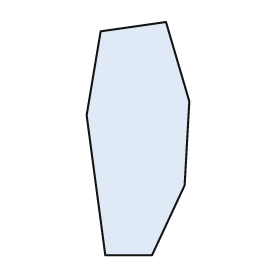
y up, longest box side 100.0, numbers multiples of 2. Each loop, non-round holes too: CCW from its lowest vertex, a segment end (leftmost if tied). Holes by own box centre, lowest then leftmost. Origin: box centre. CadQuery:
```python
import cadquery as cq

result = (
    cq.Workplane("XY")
    .moveTo(-14.0, -50.0)
    .lineTo(6.0, -50.0)
    .lineTo(20.0, -20.0)
    .lineTo(22.0, 16.0)
    .lineTo(12.0, 50.0)
    .lineTo(-16.0, 46.0)
    .lineTo(-22.0, 10.0)
    .close()
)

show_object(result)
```